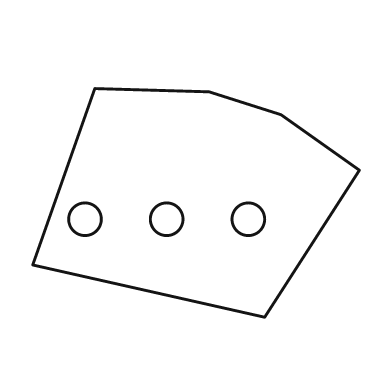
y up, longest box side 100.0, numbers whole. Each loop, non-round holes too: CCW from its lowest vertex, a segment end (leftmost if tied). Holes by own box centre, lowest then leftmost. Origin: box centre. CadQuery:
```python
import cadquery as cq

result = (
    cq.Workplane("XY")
    .moveTo(21.0, -35.0)
    .lineTo(50.0, 10.0)
    .lineTo(26.0, 27.0)
    .lineTo(4.0, 34.0)
    .lineTo(-31.0, 35.0)
    .lineTo(-50.0, -19.0)
    .close()
    .moveTo(-34.0, -5.0)
    .circle(5.0)
    .moveTo(-9.0, -5.0)
    .circle(5.0)
    .moveTo(16.0, -5.0)
    .circle(5.0)
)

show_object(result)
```